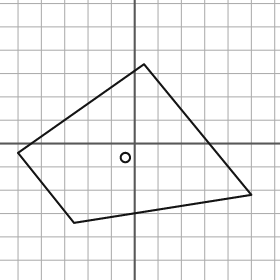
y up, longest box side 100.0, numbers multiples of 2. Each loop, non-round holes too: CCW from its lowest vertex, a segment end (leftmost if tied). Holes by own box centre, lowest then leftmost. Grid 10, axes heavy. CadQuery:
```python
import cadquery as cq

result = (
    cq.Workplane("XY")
    .moveTo(-26.0, -34.0)
    .lineTo(50.0, -22.0)
    .lineTo(4.0, 34.0)
    .lineTo(-50.0, -4.0)
    .close()
    .moveTo(-4.0, -6.0)
    .circle(2.0)
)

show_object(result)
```